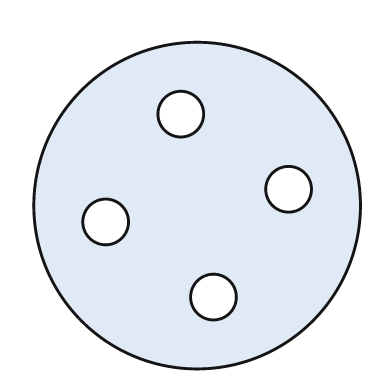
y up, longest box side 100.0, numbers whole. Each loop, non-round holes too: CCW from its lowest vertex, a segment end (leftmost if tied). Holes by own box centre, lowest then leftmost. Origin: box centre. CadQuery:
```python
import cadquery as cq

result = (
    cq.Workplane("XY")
    .moveTo(0.0, 0.0)
    .circle(50.0)
    .moveTo(5.0, -28.0)
    .circle(7.0)
    .moveTo(-28.0, -5.0)
    .circle(7.0)
    .moveTo(28.0, 5.0)
    .circle(7.0)
    .moveTo(-5.0, 28.0)
    .circle(7.0)
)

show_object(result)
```